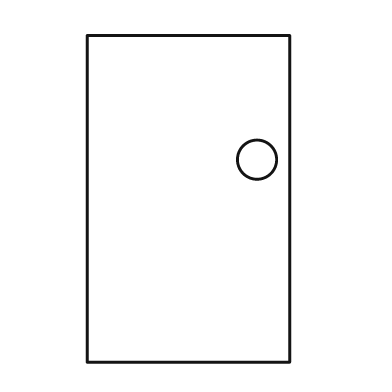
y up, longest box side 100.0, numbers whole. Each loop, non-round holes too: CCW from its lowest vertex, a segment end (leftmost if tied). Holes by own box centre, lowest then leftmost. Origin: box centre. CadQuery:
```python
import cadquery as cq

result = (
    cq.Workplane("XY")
    .moveTo(-31.0, -50.0)
    .lineTo(31.0, -50.0)
    .lineTo(31.0, 50.0)
    .lineTo(-31.0, 50.0)
    .close()
    .moveTo(21.0, 12.0)
    .circle(6.0)
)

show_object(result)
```